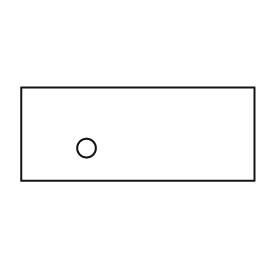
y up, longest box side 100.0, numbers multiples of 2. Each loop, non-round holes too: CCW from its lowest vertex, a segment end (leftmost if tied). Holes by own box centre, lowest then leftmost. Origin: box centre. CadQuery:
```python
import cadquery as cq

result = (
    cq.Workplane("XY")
    .moveTo(-50.0, -20.0)
    .lineTo(50.0, -20.0)
    .lineTo(50.0, 20.0)
    .lineTo(-50.0, 20.0)
    .close()
    .moveTo(-22.0, -6.0)
    .circle(4.0)
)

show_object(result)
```